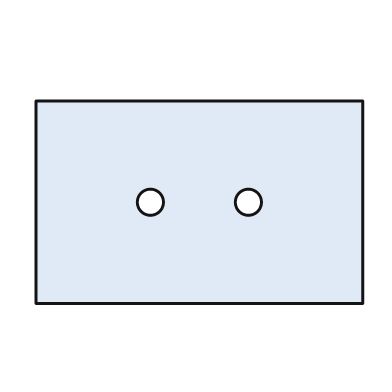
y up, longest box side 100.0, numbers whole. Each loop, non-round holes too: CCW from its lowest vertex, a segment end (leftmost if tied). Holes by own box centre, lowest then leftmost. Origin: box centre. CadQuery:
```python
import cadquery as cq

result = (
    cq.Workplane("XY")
    .moveTo(-50.0, -31.0)
    .lineTo(50.0, -31.0)
    .lineTo(50.0, 31.0)
    .lineTo(-50.0, 31.0)
    .close()
    .moveTo(-15.0, 0.0)
    .circle(4.0)
    .moveTo(15.0, 0.0)
    .circle(4.0)
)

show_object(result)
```